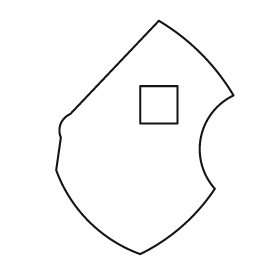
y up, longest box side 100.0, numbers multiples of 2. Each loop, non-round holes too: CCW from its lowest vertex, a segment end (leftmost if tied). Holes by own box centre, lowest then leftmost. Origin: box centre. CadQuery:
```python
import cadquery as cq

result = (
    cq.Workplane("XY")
    .moveTo(-2.0, -50.0)
    .threePointArc((16.0, -38.0), (30.0, -22.0))
    .threePointArc((24.0, 0.0), (38.0, 18.0))
    .threePointArc((24.0, 36.0), (6.0, 50.0))
    .lineTo(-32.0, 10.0)
    .threePointArc((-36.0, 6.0), (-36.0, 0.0))
    .lineTo(-38.0, -14.0)
    .threePointArc((-24.0, -36.0), (-2.0, -50.0))
    .close()
    .moveTo(-2.0, 6.0)
    .lineTo(14.0, 6.0)
    .lineTo(14.0, 22.0)
    .lineTo(-2.0, 22.0)
    .close()
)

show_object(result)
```